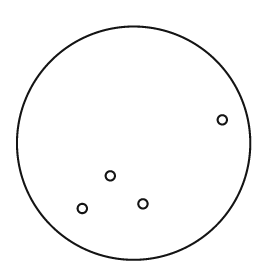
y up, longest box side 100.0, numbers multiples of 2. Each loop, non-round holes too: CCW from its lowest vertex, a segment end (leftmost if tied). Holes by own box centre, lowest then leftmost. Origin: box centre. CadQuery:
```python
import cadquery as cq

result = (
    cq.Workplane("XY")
    .moveTo(0.0, 0.0)
    .circle(50.0)
    .moveTo(-22.0, -28.0)
    .circle(2.0)
    .moveTo(4.0, -26.0)
    .circle(2.0)
    .moveTo(-10.0, -14.0)
    .circle(2.0)
    .moveTo(38.0, 10.0)
    .circle(2.0)
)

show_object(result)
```